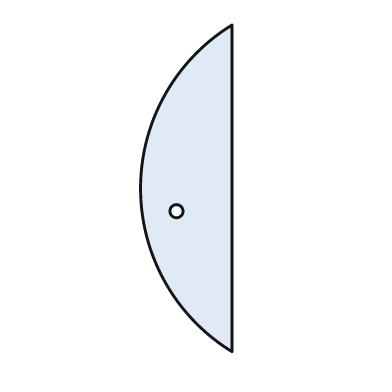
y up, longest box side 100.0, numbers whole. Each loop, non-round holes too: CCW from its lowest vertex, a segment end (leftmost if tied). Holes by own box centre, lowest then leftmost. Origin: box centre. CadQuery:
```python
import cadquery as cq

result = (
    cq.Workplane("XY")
    .moveTo(14.0, -50.0)
    .lineTo(14.0, 50.0)
    .threePointArc((-14.0, 0.0), (14.0, -50.0))
    .close()
    .moveTo(-3.0, -7.0)
    .circle(2.0)
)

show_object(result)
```